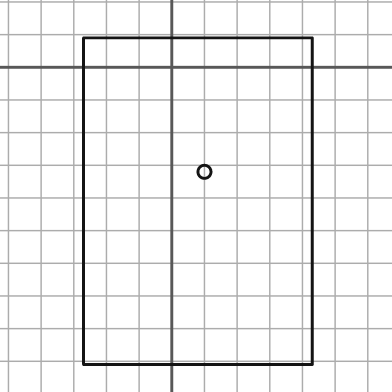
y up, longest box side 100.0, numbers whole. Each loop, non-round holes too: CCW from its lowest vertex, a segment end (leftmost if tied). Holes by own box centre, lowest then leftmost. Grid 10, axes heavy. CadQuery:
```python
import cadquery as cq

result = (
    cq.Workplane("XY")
    .moveTo(-27.0, -91.0)
    .lineTo(43.0, -91.0)
    .lineTo(43.0, 9.0)
    .lineTo(-27.0, 9.0)
    .close()
    .moveTo(10.0, -32.0)
    .circle(2.0)
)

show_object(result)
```